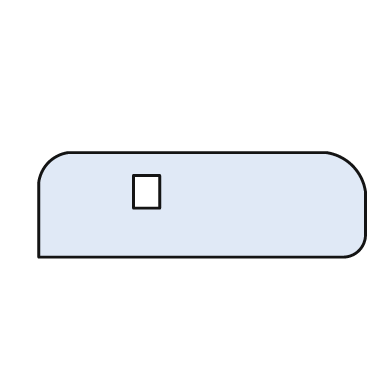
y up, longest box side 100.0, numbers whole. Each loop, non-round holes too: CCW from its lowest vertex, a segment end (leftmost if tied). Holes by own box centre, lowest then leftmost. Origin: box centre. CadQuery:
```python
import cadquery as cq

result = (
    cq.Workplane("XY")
    .moveTo(-50.0, -16.0)
    .lineTo(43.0, -16.0)
    .threePointArc((48.0, -14.0), (50.0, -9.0))
    .lineTo(50.0, 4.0)
    .threePointArc((46.0, 12.0), (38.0, 16.0))
    .lineTo(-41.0, 16.0)
    .threePointArc((-47.0, 13.0), (-50.0, 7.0))
    .close()
    .moveTo(-21.0, -1.0)
    .lineTo(-13.0, -1.0)
    .lineTo(-13.0, 9.0)
    .lineTo(-21.0, 9.0)
    .close()
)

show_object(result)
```